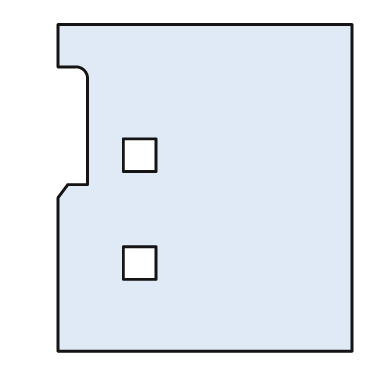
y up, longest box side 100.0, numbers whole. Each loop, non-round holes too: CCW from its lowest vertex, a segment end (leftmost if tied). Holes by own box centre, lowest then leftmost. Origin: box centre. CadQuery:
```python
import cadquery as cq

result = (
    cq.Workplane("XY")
    .moveTo(-45.0, -50.0)
    .lineTo(45.0, -50.0)
    .lineTo(45.0, 50.0)
    .lineTo(-45.0, 50.0)
    .lineTo(-45.0, 37.0)
    .lineTo(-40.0, 37.0)
    .threePointArc((-37.0, 36.0), (-36.0, 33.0))
    .lineTo(-36.0, 1.0)
    .lineTo(-42.0, 1.0)
    .lineTo(-45.0, -3.0)
    .close()
    .moveTo(-25.0, -28.0)
    .lineTo(-15.0, -28.0)
    .lineTo(-15.0, -18.0)
    .lineTo(-25.0, -18.0)
    .close()
    .moveTo(-25.0, 5.0)
    .lineTo(-15.0, 5.0)
    .lineTo(-15.0, 15.0)
    .lineTo(-25.0, 15.0)
    .close()
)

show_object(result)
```